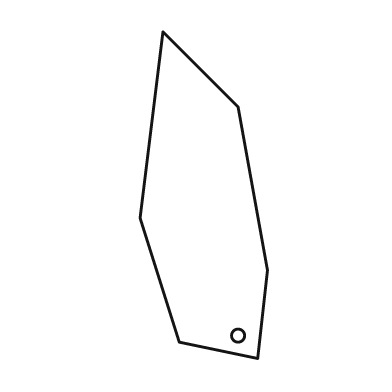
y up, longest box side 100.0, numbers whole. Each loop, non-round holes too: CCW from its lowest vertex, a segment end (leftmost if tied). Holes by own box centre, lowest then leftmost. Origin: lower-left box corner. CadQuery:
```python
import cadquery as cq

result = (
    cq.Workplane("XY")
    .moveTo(36.0, 0.0)
    .lineTo(39.0, 27.0)
    .lineTo(30.0, 77.0)
    .lineTo(7.0, 100.0)
    .lineTo(0.0, 43.0)
    .lineTo(12.0, 5.0)
    .close()
    .moveTo(30.0, 7.0)
    .circle(2.0)
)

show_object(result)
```